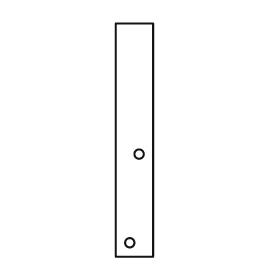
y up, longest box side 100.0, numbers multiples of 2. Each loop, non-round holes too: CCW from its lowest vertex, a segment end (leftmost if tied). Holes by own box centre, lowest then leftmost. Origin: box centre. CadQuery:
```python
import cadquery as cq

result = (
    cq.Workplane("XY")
    .moveTo(-8.0, -50.0)
    .lineTo(8.0, -50.0)
    .lineTo(8.0, 50.0)
    .lineTo(-8.0, 50.0)
    .close()
    .moveTo(-2.0, -44.0)
    .circle(2.0)
    .moveTo(2.0, -6.0)
    .circle(2.0)
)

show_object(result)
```